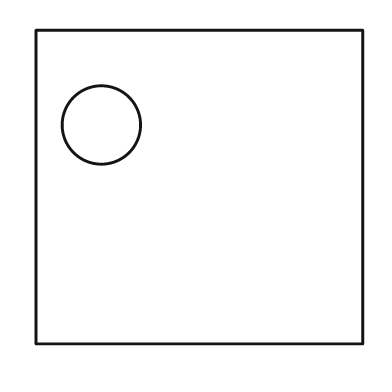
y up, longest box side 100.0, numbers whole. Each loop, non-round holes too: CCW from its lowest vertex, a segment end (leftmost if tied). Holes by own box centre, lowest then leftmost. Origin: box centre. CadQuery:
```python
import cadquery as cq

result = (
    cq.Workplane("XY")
    .moveTo(-50.0, -48.0)
    .lineTo(50.0, -48.0)
    .lineTo(50.0, 48.0)
    .lineTo(-50.0, 48.0)
    .close()
    .moveTo(-30.0, 19.0)
    .circle(12.0)
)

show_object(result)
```